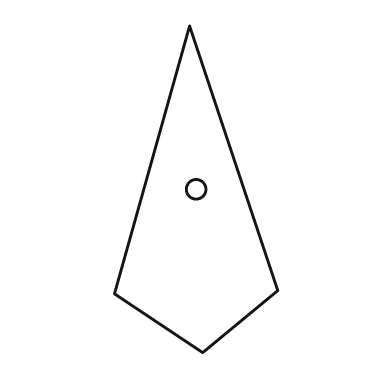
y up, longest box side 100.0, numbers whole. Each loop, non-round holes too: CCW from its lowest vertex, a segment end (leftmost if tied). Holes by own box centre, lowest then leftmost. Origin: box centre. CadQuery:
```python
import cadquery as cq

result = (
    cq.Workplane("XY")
    .moveTo(2.0, -50.0)
    .lineTo(25.0, -31.0)
    .lineTo(-2.0, 50.0)
    .lineTo(-25.0, -32.0)
    .close()
    .moveTo(0.0, 0.0)
    .circle(3.0)
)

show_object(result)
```